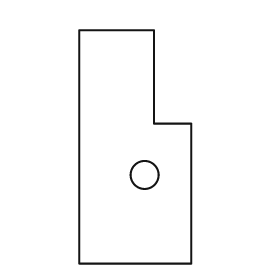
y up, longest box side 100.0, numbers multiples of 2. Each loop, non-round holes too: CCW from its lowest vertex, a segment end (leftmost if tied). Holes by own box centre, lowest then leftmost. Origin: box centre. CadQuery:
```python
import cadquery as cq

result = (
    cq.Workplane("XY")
    .moveTo(-24.0, -50.0)
    .lineTo(24.0, -50.0)
    .lineTo(24.0, 10.0)
    .lineTo(8.0, 10.0)
    .lineTo(8.0, 50.0)
    .lineTo(-24.0, 50.0)
    .close()
    .moveTo(4.0, -12.0)
    .circle(6.0)
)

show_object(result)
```